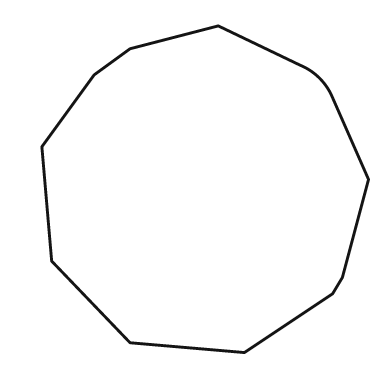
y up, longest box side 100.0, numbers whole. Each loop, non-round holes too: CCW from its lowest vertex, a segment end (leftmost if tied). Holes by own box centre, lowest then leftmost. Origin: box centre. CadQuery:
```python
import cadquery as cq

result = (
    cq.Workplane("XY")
    .moveTo(12.0, -50.0)
    .lineTo(39.0, -32.0)
    .lineTo(42.0, -27.0)
    .lineTo(50.0, 3.0)
    .lineTo(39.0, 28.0)
    .threePointArc((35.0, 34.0), (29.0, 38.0))
    .lineTo(4.0, 50.0)
    .lineTo(-23.0, 43.0)
    .lineTo(-34.0, 35.0)
    .lineTo(-50.0, 13.0)
    .lineTo(-47.0, -22.0)
    .lineTo(-23.0, -47.0)
    .close()
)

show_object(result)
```